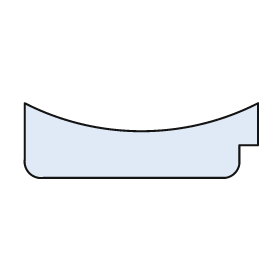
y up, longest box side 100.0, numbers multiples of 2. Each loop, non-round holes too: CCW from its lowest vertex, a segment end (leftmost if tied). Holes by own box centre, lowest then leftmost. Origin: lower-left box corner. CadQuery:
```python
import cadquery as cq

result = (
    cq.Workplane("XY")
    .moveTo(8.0, 0.0)
    .lineTo(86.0, 0.0)
    .threePointArc((90.0, 2.0), (92.0, 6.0))
    .lineTo(92.0, 14.0)
    .lineTo(100.0, 14.0)
    .lineTo(100.0, 32.0)
    .threePointArc((50.0, 20.0), (0.0, 32.0))
    .lineTo(0.0, 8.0)
    .threePointArc((2.0, 2.0), (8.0, 0.0))
    .close()
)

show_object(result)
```